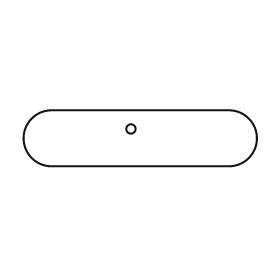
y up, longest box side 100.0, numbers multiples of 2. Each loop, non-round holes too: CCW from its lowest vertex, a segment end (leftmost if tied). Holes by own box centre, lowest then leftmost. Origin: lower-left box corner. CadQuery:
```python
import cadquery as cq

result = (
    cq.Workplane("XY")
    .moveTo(12.0, 0.0)
    .lineTo(88.0, 0.0)
    .threePointArc((100.0, 12.0), (88.0, 24.0))
    .lineTo(12.0, 24.0)
    .threePointArc((0.0, 12.0), (12.0, 0.0))
    .close()
    .moveTo(46.0, 16.0)
    .circle(2.0)
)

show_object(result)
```